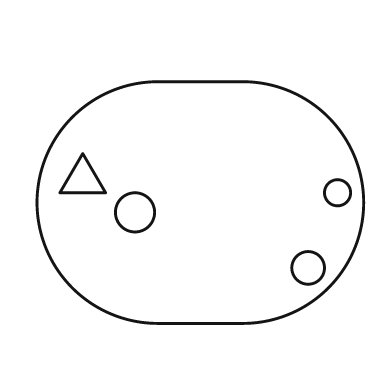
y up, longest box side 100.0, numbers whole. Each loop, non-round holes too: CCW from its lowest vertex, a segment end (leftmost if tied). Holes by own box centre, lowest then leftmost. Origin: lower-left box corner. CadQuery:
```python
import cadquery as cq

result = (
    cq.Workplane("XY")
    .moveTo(37.0, 0.0)
    .lineTo(63.0, 0.0)
    .threePointArc((100.0, 37.0), (63.0, 74.0))
    .lineTo(37.0, 74.0)
    .threePointArc((0.0, 37.0), (37.0, 0.0))
    .close()
    .moveTo(83.0, 17.0)
    .circle(5.0)
    .moveTo(30.0, 34.0)
    .circle(6.0)
    .moveTo(92.0, 40.0)
    .circle(4.0)
    .moveTo(7.0, 40.0)
    .lineTo(21.0, 40.0)
    .lineTo(14.0, 52.0)
    .close()
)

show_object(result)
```